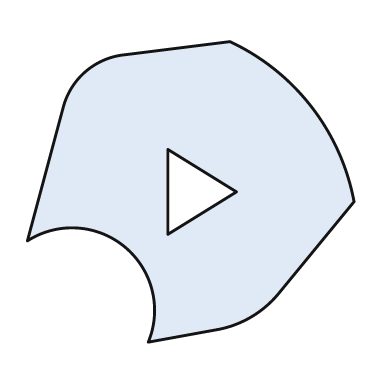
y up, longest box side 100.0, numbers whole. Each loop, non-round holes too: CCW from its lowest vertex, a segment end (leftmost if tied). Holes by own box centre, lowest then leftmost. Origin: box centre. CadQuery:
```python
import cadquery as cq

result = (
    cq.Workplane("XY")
    .moveTo(-13.0, -46.0)
    .lineTo(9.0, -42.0)
    .threePointArc((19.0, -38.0), (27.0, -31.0))
    .lineTo(50.0, -3.0)
    .threePointArc((37.0, 26.0), (12.0, 46.0))
    .lineTo(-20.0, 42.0)
    .threePointArc((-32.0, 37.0), (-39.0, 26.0))
    .lineTo(-50.0, -15.0)
    .threePointArc((-20.0, -17.0), (-13.0, -46.0))
    .close()
    .moveTo(-7.0, -13.0)
    .lineTo(14.0, 0.0)
    .lineTo(-7.0, 13.0)
    .close()
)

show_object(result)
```